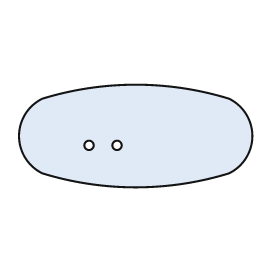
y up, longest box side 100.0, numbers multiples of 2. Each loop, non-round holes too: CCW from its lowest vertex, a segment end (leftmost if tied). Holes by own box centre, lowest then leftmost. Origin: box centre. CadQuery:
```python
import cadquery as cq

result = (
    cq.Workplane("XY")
    .moveTo(-40.0, -16.0)
    .threePointArc((0.0, -22.0), (40.0, -16.0))
    .threePointArc((50.0, 0.0), (40.0, 16.0))
    .threePointArc((0.0, 22.0), (-40.0, 16.0))
    .threePointArc((-50.0, 0.0), (-40.0, -16.0))
    .close()
    .moveTo(-20.0, -4.0)
    .circle(2.0)
    .moveTo(-8.0, -4.0)
    .circle(2.0)
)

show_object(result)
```